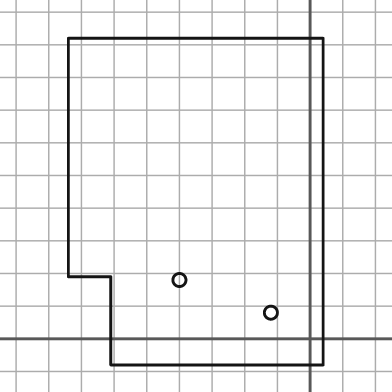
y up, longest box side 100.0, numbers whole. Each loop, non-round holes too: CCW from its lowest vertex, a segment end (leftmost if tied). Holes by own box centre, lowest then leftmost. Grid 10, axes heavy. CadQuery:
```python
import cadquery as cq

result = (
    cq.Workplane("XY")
    .moveTo(-61.0, -8.0)
    .lineTo(4.0, -8.0)
    .lineTo(4.0, 92.0)
    .lineTo(-74.0, 92.0)
    .lineTo(-74.0, 19.0)
    .lineTo(-61.0, 19.0)
    .close()
    .moveTo(-12.0, 8.0)
    .circle(2.0)
    .moveTo(-40.0, 18.0)
    .circle(2.0)
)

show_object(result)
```